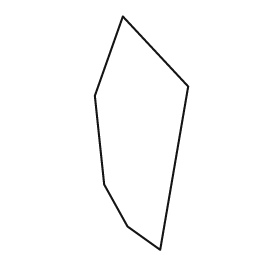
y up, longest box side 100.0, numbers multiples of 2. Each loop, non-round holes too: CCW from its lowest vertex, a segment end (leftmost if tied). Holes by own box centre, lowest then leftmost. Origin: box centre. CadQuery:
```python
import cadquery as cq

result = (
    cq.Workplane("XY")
    .moveTo(8.0, -50.0)
    .lineTo(20.0, 20.0)
    .lineTo(-8.0, 50.0)
    .lineTo(-20.0, 16.0)
    .lineTo(-16.0, -22.0)
    .lineTo(-6.0, -40.0)
    .close()
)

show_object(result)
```